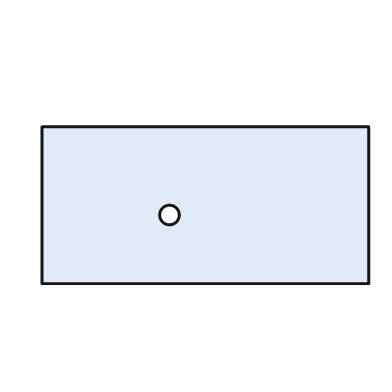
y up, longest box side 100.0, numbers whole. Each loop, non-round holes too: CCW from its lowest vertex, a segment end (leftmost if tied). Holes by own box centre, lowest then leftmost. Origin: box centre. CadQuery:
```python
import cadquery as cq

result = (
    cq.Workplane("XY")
    .moveTo(-50.0, -24.0)
    .lineTo(50.0, -24.0)
    .lineTo(50.0, 24.0)
    .lineTo(-50.0, 24.0)
    .close()
    .moveTo(-11.0, -3.0)
    .circle(3.0)
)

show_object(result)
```